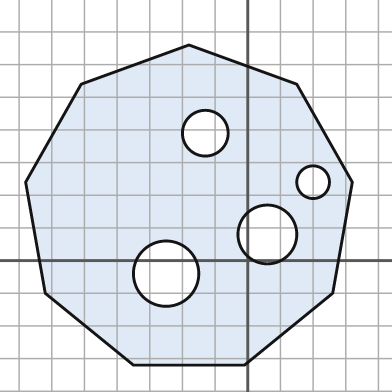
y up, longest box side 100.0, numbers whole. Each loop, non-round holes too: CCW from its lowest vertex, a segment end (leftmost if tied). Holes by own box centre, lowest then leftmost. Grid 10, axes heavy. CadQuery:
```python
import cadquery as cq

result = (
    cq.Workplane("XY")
    .moveTo(-35.0, -32.0)
    .lineTo(-1.0, -32.0)
    .lineTo(26.0, -10.0)
    .lineTo(32.0, 24.0)
    .lineTo(15.0, 54.0)
    .lineTo(-18.0, 66.0)
    .lineTo(-51.0, 54.0)
    .lineTo(-68.0, 24.0)
    .lineTo(-62.0, -10.0)
    .close()
    .moveTo(-25.0, -4.0)
    .circle(10.0)
    .moveTo(6.0, 8.0)
    .circle(9.0)
    .moveTo(20.0, 24.0)
    .circle(5.0)
    .moveTo(-13.0, 39.0)
    .circle(7.0)
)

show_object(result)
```